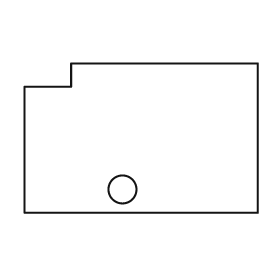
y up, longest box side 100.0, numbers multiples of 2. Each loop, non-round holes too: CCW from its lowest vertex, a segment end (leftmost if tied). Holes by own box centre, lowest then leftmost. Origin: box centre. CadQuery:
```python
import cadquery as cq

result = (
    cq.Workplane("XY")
    .moveTo(-50.0, -32.0)
    .lineTo(50.0, -32.0)
    .lineTo(50.0, 32.0)
    .lineTo(-30.0, 32.0)
    .lineTo(-30.0, 22.0)
    .lineTo(-50.0, 22.0)
    .close()
    .moveTo(-8.0, -22.0)
    .circle(6.0)
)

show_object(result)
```